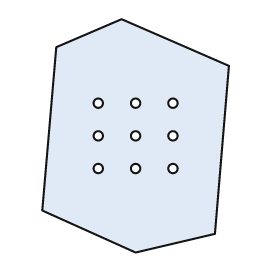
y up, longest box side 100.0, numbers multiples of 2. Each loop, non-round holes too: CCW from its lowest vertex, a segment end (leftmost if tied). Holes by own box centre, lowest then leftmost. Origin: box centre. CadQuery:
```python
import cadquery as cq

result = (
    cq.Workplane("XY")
    .moveTo(0.0, -50.0)
    .lineTo(34.0, -42.0)
    .lineTo(40.0, 30.0)
    .lineTo(-6.0, 50.0)
    .lineTo(-34.0, 38.0)
    .lineTo(-40.0, -32.0)
    .close()
    .moveTo(-16.0, -14.0)
    .circle(2.0)
    .moveTo(0.0, -14.0)
    .circle(2.0)
    .moveTo(16.0, -14.0)
    .circle(2.0)
    .moveTo(-16.0, 0.0)
    .circle(2.0)
    .moveTo(0.0, 0.0)
    .circle(2.0)
    .moveTo(16.0, 0.0)
    .circle(2.0)
    .moveTo(-16.0, 14.0)
    .circle(2.0)
    .moveTo(0.0, 14.0)
    .circle(2.0)
    .moveTo(16.0, 14.0)
    .circle(2.0)
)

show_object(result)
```